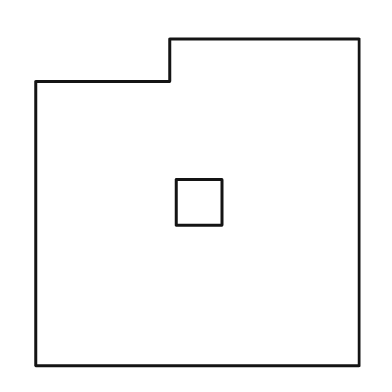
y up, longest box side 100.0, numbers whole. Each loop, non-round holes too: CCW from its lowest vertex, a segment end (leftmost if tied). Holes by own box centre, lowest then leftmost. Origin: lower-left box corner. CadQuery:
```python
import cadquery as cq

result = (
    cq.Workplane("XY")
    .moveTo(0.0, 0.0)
    .lineTo(99.0, 0.0)
    .lineTo(99.0, 100.0)
    .lineTo(41.0, 100.0)
    .lineTo(41.0, 87.0)
    .lineTo(0.0, 87.0)
    .close()
    .moveTo(43.0, 43.0)
    .lineTo(57.0, 43.0)
    .lineTo(57.0, 57.0)
    .lineTo(43.0, 57.0)
    .close()
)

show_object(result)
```